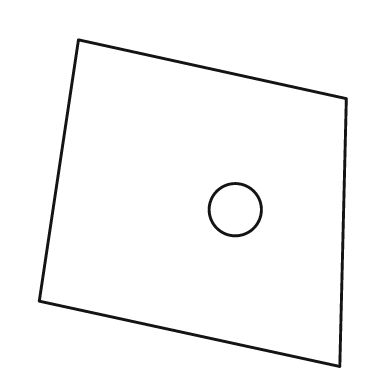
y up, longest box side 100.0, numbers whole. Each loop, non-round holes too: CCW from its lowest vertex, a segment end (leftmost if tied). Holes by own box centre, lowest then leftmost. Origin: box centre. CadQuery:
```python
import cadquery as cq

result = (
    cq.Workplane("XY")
    .moveTo(45.0, -50.0)
    .lineTo(47.0, 32.0)
    .lineTo(-35.0, 50.0)
    .lineTo(-47.0, -30.0)
    .close()
    .moveTo(13.0, -2.0)
    .circle(8.0)
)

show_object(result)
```